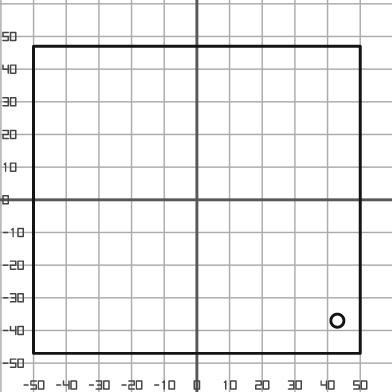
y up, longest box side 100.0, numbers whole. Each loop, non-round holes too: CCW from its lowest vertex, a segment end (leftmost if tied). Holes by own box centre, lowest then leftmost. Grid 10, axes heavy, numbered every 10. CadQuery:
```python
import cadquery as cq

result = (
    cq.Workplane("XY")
    .moveTo(-50.0, -47.0)
    .lineTo(50.0, -47.0)
    .lineTo(50.0, 47.0)
    .lineTo(-50.0, 47.0)
    .close()
    .moveTo(43.0, -37.0)
    .circle(2.0)
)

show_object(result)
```